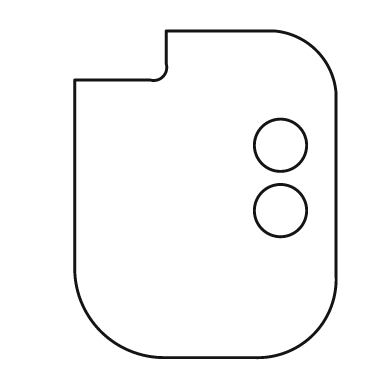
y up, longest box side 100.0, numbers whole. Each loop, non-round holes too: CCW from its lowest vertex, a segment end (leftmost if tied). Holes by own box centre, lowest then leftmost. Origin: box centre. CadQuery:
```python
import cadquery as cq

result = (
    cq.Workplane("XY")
    .moveTo(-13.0, -50.0)
    .lineTo(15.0, -50.0)
    .threePointArc((33.0, -43.0), (40.0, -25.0))
    .lineTo(40.0, 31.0)
    .threePointArc((34.0, 44.0), (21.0, 50.0))
    .lineTo(-12.0, 50.0)
    .lineTo(-12.0, 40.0)
    .threePointArc((-13.0, 36.0), (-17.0, 35.0))
    .lineTo(-40.0, 35.0)
    .lineTo(-40.0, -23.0)
    .threePointArc((-32.0, -42.0), (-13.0, -50.0))
    .close()
    .moveTo(23.0, -5.0)
    .circle(8.0)
    .moveTo(23.0, 15.0)
    .circle(8.0)
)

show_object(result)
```